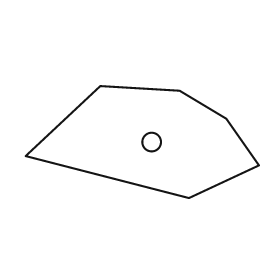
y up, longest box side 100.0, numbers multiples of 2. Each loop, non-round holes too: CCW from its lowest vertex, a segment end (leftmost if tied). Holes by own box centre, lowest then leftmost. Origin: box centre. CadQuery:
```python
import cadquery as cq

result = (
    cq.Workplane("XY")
    .moveTo(20.0, -24.0)
    .lineTo(50.0, -10.0)
    .lineTo(36.0, 10.0)
    .lineTo(16.0, 22.0)
    .lineTo(-18.0, 24.0)
    .lineTo(-50.0, -6.0)
    .close()
    .moveTo(4.0, 0.0)
    .circle(4.0)
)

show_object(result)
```